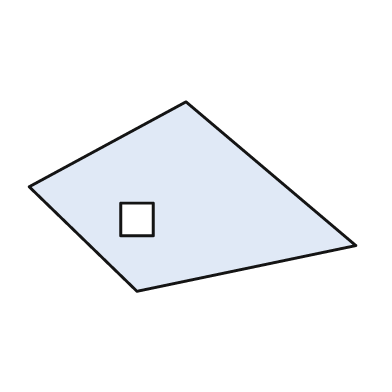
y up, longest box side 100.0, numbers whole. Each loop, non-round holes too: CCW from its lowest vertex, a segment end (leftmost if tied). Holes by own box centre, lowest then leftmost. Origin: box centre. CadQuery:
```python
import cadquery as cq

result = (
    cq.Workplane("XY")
    .moveTo(-17.0, -29.0)
    .lineTo(50.0, -15.0)
    .lineTo(-2.0, 29.0)
    .lineTo(-50.0, 3.0)
    .close()
    .moveTo(-22.0, -12.0)
    .lineTo(-12.0, -12.0)
    .lineTo(-12.0, -2.0)
    .lineTo(-22.0, -2.0)
    .close()
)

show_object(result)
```